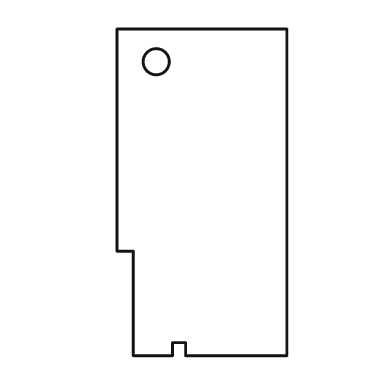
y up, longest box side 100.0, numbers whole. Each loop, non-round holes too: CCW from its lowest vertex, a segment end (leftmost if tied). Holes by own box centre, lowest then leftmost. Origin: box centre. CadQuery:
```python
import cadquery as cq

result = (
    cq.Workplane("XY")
    .moveTo(-21.0, -50.0)
    .lineTo(-9.0, -50.0)
    .lineTo(-9.0, -46.0)
    .lineTo(-5.0, -46.0)
    .lineTo(-5.0, -50.0)
    .lineTo(26.0, -50.0)
    .lineTo(26.0, 50.0)
    .lineTo(-26.0, 50.0)
    .lineTo(-26.0, -18.0)
    .lineTo(-21.0, -18.0)
    .close()
    .moveTo(-14.0, 40.0)
    .circle(4.0)
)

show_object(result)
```